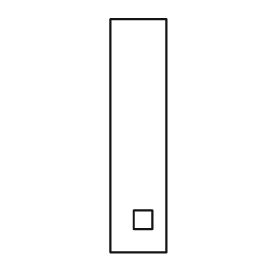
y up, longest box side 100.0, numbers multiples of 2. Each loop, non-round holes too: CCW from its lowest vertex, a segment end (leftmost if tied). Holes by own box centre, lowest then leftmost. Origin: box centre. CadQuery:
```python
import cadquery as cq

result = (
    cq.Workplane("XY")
    .moveTo(-12.0, -50.0)
    .lineTo(12.0, -50.0)
    .lineTo(12.0, 50.0)
    .lineTo(-12.0, 50.0)
    .close()
    .moveTo(-2.0, -40.0)
    .lineTo(6.0, -40.0)
    .lineTo(6.0, -32.0)
    .lineTo(-2.0, -32.0)
    .close()
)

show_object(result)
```